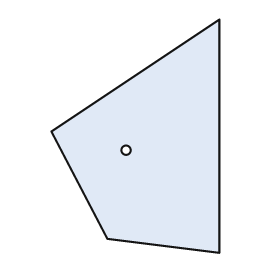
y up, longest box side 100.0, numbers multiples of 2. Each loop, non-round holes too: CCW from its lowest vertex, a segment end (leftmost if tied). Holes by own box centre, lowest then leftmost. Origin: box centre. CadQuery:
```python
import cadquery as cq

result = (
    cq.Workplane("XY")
    .moveTo(36.0, -50.0)
    .lineTo(36.0, 50.0)
    .lineTo(-36.0, 2.0)
    .lineTo(-12.0, -44.0)
    .close()
    .moveTo(-4.0, -6.0)
    .circle(2.0)
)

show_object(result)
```